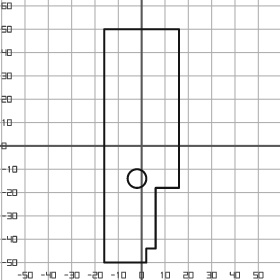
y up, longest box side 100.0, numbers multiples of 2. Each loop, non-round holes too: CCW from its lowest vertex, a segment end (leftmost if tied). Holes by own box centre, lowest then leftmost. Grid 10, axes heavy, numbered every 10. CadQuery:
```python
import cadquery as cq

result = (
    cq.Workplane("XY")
    .moveTo(-16.0, -50.0)
    .lineTo(2.0, -50.0)
    .lineTo(2.0, -44.0)
    .lineTo(6.0, -44.0)
    .lineTo(6.0, -18.0)
    .lineTo(16.0, -18.0)
    .lineTo(16.0, 50.0)
    .lineTo(-16.0, 50.0)
    .close()
    .moveTo(-2.0, -14.0)
    .circle(4.0)
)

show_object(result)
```